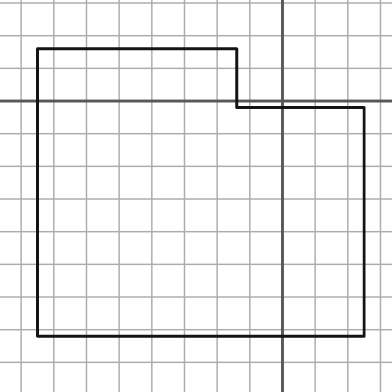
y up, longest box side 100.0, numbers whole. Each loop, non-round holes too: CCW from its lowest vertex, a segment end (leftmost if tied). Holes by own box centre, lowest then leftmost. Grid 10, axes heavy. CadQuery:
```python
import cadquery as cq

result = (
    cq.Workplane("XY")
    .moveTo(-75.0, -72.0)
    .lineTo(25.0, -72.0)
    .lineTo(25.0, -2.0)
    .lineTo(-14.0, -2.0)
    .lineTo(-14.0, 16.0)
    .lineTo(-75.0, 16.0)
    .close()
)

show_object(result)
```